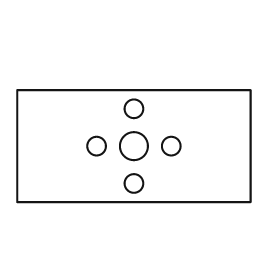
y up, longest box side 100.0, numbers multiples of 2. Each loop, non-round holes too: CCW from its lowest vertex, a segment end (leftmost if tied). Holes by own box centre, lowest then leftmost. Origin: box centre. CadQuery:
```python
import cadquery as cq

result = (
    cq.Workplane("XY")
    .moveTo(-50.0, -24.0)
    .lineTo(50.0, -24.0)
    .lineTo(50.0, 24.0)
    .lineTo(-50.0, 24.0)
    .close()
    .moveTo(0.0, -16.0)
    .circle(4.0)
    .moveTo(-16.0, 0.0)
    .circle(4.0)
    .moveTo(0.0, 0.0)
    .circle(6.0)
    .moveTo(16.0, 0.0)
    .circle(4.0)
    .moveTo(0.0, 16.0)
    .circle(4.0)
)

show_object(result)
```